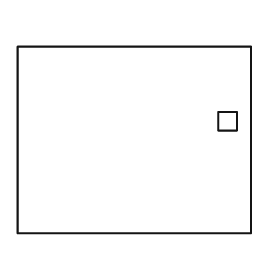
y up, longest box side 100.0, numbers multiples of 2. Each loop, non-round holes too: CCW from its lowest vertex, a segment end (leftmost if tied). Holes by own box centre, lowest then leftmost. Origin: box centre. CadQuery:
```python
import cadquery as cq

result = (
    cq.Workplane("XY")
    .moveTo(-50.0, -40.0)
    .lineTo(50.0, -40.0)
    .lineTo(50.0, 40.0)
    .lineTo(-50.0, 40.0)
    .close()
    .moveTo(36.0, 4.0)
    .lineTo(44.0, 4.0)
    .lineTo(44.0, 12.0)
    .lineTo(36.0, 12.0)
    .close()
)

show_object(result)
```